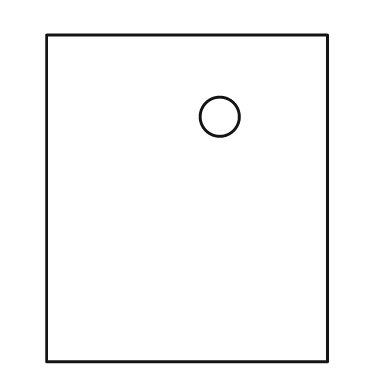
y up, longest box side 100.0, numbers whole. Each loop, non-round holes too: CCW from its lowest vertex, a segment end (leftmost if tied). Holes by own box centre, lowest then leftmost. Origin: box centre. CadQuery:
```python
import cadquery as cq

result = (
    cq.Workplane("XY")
    .moveTo(-43.0, -50.0)
    .lineTo(43.0, -50.0)
    .lineTo(43.0, 50.0)
    .lineTo(-43.0, 50.0)
    .close()
    .moveTo(10.0, 25.0)
    .circle(6.0)
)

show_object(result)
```